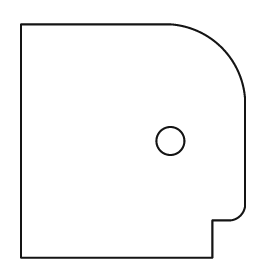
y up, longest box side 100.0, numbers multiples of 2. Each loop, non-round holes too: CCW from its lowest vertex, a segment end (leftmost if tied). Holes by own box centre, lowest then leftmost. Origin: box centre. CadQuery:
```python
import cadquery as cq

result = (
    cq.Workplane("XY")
    .moveTo(-48.0, -50.0)
    .lineTo(34.0, -50.0)
    .lineTo(34.0, -34.0)
    .lineTo(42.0, -34.0)
    .threePointArc((46.0, -32.0), (48.0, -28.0))
    .lineTo(48.0, 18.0)
    .threePointArc((38.0, 40.0), (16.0, 50.0))
    .lineTo(-48.0, 50.0)
    .close()
    .moveTo(16.0, 0.0)
    .circle(6.0)
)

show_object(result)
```